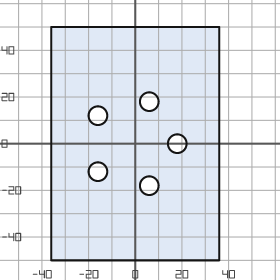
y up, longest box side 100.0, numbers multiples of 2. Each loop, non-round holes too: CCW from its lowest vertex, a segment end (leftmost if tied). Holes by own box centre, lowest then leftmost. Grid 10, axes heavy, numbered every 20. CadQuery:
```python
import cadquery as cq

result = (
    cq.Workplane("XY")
    .moveTo(-36.0, -50.0)
    .lineTo(36.0, -50.0)
    .lineTo(36.0, 50.0)
    .lineTo(-36.0, 50.0)
    .close()
    .moveTo(6.0, -18.0)
    .circle(4.0)
    .moveTo(-16.0, -12.0)
    .circle(4.0)
    .moveTo(18.0, 0.0)
    .circle(4.0)
    .moveTo(-16.0, 12.0)
    .circle(4.0)
    .moveTo(6.0, 18.0)
    .circle(4.0)
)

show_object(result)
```